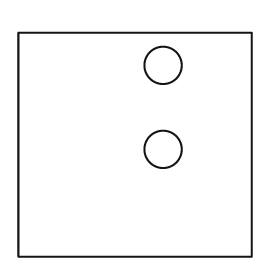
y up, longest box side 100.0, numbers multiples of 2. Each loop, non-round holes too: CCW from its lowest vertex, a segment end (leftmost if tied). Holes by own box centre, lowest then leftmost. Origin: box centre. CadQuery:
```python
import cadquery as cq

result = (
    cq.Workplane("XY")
    .moveTo(-50.0, -48.0)
    .lineTo(50.0, -48.0)
    .lineTo(50.0, 48.0)
    .lineTo(-50.0, 48.0)
    .close()
    .moveTo(12.0, -2.0)
    .circle(8.0)
    .moveTo(12.0, 34.0)
    .circle(8.0)
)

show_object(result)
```